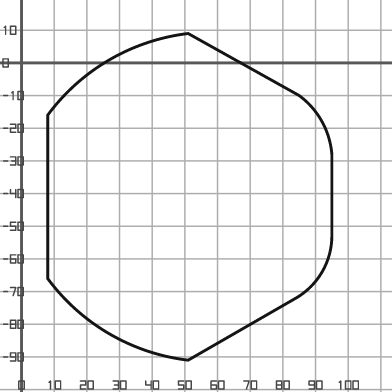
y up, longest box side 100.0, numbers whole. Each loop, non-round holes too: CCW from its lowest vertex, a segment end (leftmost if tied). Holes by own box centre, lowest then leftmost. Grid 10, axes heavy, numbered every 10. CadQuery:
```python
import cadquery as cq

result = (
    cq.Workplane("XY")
    .moveTo(51.0, -91.0)
    .lineTo(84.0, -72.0)
    .threePointArc((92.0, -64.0), (95.0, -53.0))
    .lineTo(95.0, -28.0)
    .threePointArc((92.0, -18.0), (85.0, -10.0))
    .lineTo(51.0, 9.0)
    .threePointArc((27.0, 1.0), (8.0, -16.0))
    .lineTo(8.0, -66.0)
    .threePointArc((27.0, -83.0), (51.0, -91.0))
    .close()
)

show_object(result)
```